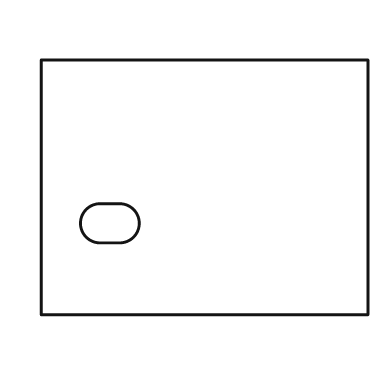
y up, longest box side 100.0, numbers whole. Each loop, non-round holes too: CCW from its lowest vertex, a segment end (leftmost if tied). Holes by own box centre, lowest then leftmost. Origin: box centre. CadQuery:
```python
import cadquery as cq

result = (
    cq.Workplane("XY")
    .moveTo(-50.0, -39.0)
    .lineTo(50.0, -39.0)
    .lineTo(50.0, 39.0)
    .lineTo(-50.0, 39.0)
    .close()
    .moveTo(-32.0, -17.0)
    .lineTo(-26.0, -17.0)
    .threePointArc((-20.0, -11.0), (-26.0, -5.0))
    .lineTo(-32.0, -5.0)
    .threePointArc((-38.0, -11.0), (-32.0, -17.0))
    .close()
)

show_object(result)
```